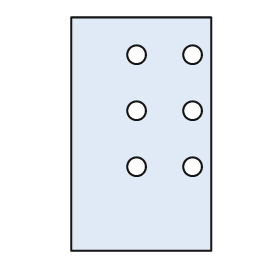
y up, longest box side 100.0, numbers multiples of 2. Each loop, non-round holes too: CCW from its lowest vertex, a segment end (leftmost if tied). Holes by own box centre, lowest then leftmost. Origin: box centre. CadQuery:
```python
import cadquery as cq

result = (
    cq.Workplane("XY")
    .moveTo(-30.0, -50.0)
    .lineTo(30.0, -50.0)
    .lineTo(30.0, 50.0)
    .lineTo(-30.0, 50.0)
    .close()
    .moveTo(-2.0, -14.0)
    .circle(4.0)
    .moveTo(22.0, -14.0)
    .circle(4.0)
    .moveTo(-2.0, 10.0)
    .circle(4.0)
    .moveTo(22.0, 10.0)
    .circle(4.0)
    .moveTo(-2.0, 34.0)
    .circle(4.0)
    .moveTo(22.0, 34.0)
    .circle(4.0)
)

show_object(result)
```